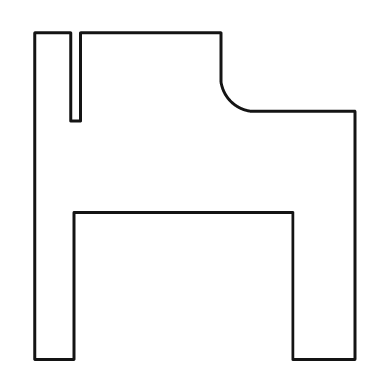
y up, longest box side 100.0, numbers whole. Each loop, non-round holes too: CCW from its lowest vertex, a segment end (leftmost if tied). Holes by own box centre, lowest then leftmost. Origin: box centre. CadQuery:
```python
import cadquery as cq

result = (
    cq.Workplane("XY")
    .moveTo(-49.0, -50.0)
    .lineTo(-37.0, -50.0)
    .lineTo(-37.0, -5.0)
    .lineTo(30.0, -5.0)
    .lineTo(30.0, -50.0)
    .lineTo(49.0, -50.0)
    .lineTo(49.0, 26.0)
    .lineTo(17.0, 26.0)
    .threePointArc((11.0, 29.0), (8.0, 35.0))
    .lineTo(8.0, 50.0)
    .lineTo(-35.0, 50.0)
    .lineTo(-35.0, 23.0)
    .lineTo(-38.0, 23.0)
    .lineTo(-38.0, 50.0)
    .lineTo(-49.0, 50.0)
    .close()
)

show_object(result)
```